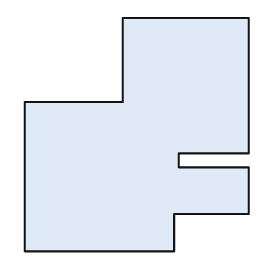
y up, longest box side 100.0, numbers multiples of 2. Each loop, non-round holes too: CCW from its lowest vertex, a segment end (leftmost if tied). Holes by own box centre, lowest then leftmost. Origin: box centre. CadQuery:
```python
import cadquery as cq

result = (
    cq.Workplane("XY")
    .moveTo(-48.0, -50.0)
    .lineTo(16.0, -50.0)
    .lineTo(16.0, -34.0)
    .lineTo(48.0, -34.0)
    .lineTo(48.0, -14.0)
    .lineTo(18.0, -14.0)
    .lineTo(18.0, -8.0)
    .lineTo(48.0, -8.0)
    .lineTo(48.0, 50.0)
    .lineTo(-6.0, 50.0)
    .lineTo(-6.0, 14.0)
    .lineTo(-48.0, 14.0)
    .close()
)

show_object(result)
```